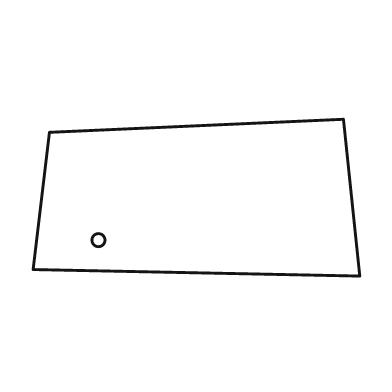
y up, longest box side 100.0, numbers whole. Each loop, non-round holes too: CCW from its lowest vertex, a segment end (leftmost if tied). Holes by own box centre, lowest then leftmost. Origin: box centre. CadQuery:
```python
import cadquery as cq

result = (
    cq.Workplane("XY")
    .moveTo(50.0, -24.0)
    .lineTo(45.0, 24.0)
    .lineTo(-45.0, 20.0)
    .lineTo(-50.0, -22.0)
    .close()
    .moveTo(-30.0, -13.0)
    .circle(2.0)
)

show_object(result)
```